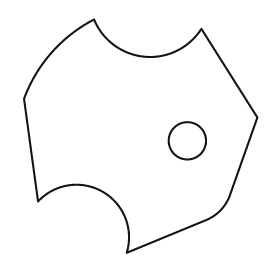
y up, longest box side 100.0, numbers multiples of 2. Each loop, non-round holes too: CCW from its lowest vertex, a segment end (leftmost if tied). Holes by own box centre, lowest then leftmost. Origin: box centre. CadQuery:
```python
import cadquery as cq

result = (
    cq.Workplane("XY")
    .moveTo(-6.0, -50.0)
    .lineTo(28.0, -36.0)
    .threePointArc((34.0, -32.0), (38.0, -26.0))
    .lineTo(50.0, 8.0)
    .lineTo(26.0, 46.0)
    .threePointArc((2.0, 34.0), (-20.0, 50.0))
    .threePointArc((-38.0, 36.0), (-50.0, 16.0))
    .lineTo(-44.0, -28.0)
    .threePointArc((-16.0, -24.0), (-6.0, -50.0))
    .close()
    .moveTo(20.0, -2.0)
    .circle(8.0)
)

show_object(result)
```